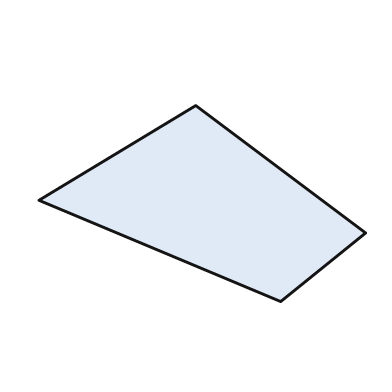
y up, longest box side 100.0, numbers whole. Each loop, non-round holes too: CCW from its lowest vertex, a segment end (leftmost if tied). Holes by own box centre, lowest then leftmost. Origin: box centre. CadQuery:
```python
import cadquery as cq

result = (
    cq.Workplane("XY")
    .moveTo(24.0, -30.0)
    .lineTo(50.0, -9.0)
    .lineTo(-2.0, 30.0)
    .lineTo(-50.0, 1.0)
    .close()
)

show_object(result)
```